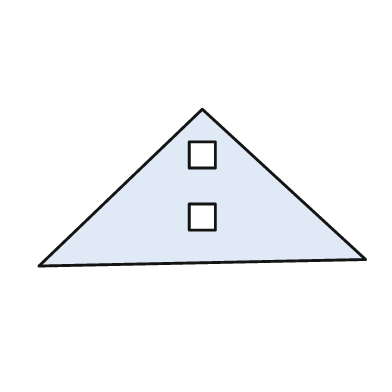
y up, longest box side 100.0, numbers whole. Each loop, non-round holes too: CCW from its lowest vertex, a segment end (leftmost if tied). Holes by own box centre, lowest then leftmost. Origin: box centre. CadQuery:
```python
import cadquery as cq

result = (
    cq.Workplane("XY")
    .moveTo(-50.0, -24.0)
    .lineTo(50.0, -22.0)
    .lineTo(0.0, 24.0)
    .close()
    .moveTo(-4.0, -13.0)
    .lineTo(4.0, -13.0)
    .lineTo(4.0, -5.0)
    .lineTo(-4.0, -5.0)
    .close()
    .moveTo(-4.0, 6.0)
    .lineTo(4.0, 6.0)
    .lineTo(4.0, 14.0)
    .lineTo(-4.0, 14.0)
    .close()
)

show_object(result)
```